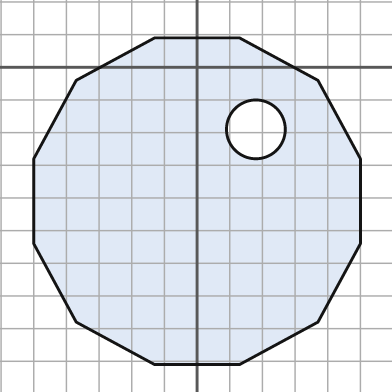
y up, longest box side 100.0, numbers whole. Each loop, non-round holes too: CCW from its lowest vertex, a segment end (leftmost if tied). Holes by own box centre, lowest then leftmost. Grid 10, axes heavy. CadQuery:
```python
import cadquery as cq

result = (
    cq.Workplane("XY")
    .moveTo(-13.0, -91.0)
    .lineTo(13.0, -91.0)
    .lineTo(37.0, -78.0)
    .lineTo(50.0, -54.0)
    .lineTo(50.0, -28.0)
    .lineTo(37.0, -4.0)
    .lineTo(13.0, 9.0)
    .lineTo(-13.0, 9.0)
    .lineTo(-37.0, -4.0)
    .lineTo(-50.0, -28.0)
    .lineTo(-50.0, -54.0)
    .lineTo(-37.0, -78.0)
    .close()
    .moveTo(18.0, -19.0)
    .circle(9.0)
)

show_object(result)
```